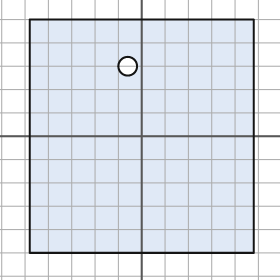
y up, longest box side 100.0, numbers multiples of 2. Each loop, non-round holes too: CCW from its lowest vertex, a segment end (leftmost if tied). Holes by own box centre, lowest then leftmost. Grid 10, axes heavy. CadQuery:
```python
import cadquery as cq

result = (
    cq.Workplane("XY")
    .moveTo(-48.0, -50.0)
    .lineTo(48.0, -50.0)
    .lineTo(48.0, 50.0)
    .lineTo(-48.0, 50.0)
    .close()
    .moveTo(-6.0, 30.0)
    .circle(4.0)
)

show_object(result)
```